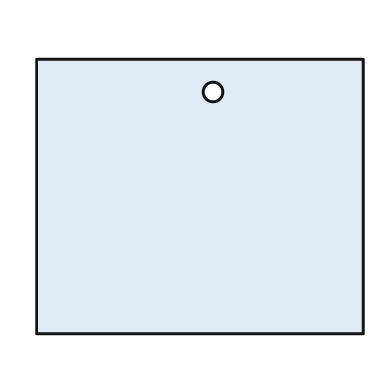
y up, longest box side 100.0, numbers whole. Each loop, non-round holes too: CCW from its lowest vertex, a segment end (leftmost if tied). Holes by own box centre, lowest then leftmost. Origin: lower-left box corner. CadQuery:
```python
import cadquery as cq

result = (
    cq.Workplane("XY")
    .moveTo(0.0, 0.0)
    .lineTo(100.0, 0.0)
    .lineTo(100.0, 84.0)
    .lineTo(0.0, 84.0)
    .close()
    .moveTo(54.0, 74.0)
    .circle(3.0)
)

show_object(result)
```